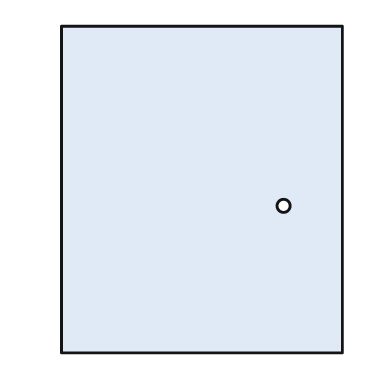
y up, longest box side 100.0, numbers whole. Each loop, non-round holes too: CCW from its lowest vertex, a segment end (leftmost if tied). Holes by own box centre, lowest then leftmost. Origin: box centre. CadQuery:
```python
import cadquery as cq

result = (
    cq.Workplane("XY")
    .moveTo(-43.0, -50.0)
    .lineTo(43.0, -50.0)
    .lineTo(43.0, 50.0)
    .lineTo(-43.0, 50.0)
    .close()
    .moveTo(25.0, -5.0)
    .circle(2.0)
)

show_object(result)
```